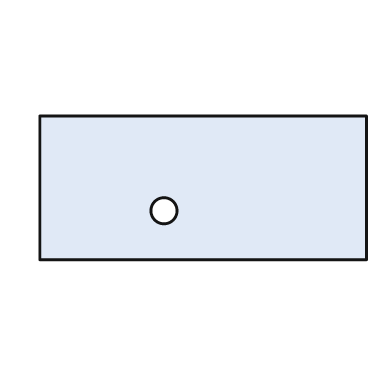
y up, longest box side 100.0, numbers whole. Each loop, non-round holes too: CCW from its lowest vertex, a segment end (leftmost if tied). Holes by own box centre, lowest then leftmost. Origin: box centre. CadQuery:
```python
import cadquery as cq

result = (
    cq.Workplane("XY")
    .moveTo(-50.0, -22.0)
    .lineTo(50.0, -22.0)
    .lineTo(50.0, 22.0)
    .lineTo(-50.0, 22.0)
    .close()
    .moveTo(-12.0, -7.0)
    .circle(4.0)
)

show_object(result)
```